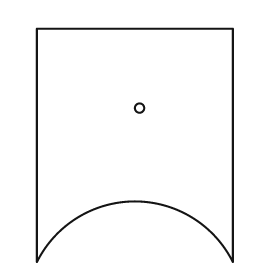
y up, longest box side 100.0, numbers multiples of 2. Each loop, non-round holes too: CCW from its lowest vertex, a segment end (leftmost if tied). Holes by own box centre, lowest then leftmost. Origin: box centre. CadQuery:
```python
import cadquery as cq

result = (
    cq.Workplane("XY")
    .moveTo(-42.0, -50.0)
    .threePointArc((0.0, -24.0), (42.0, -50.0))
    .lineTo(42.0, 50.0)
    .lineTo(-42.0, 50.0)
    .close()
    .moveTo(2.0, 16.0)
    .circle(2.0)
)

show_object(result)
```